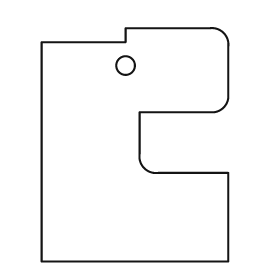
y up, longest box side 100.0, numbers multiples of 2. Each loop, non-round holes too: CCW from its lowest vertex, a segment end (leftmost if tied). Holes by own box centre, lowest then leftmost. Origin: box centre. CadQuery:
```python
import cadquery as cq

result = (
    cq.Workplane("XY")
    .moveTo(-40.0, -50.0)
    .lineTo(40.0, -50.0)
    .lineTo(40.0, -12.0)
    .lineTo(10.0, -12.0)
    .threePointArc((4.0, -10.0), (2.0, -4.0))
    .lineTo(2.0, 14.0)
    .lineTo(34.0, 14.0)
    .threePointArc((38.0, 16.0), (40.0, 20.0))
    .lineTo(40.0, 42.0)
    .threePointArc((38.0, 48.0), (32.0, 50.0))
    .lineTo(-4.0, 50.0)
    .lineTo(-4.0, 44.0)
    .lineTo(-40.0, 44.0)
    .close()
    .moveTo(-4.0, 34.0)
    .circle(4.0)
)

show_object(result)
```